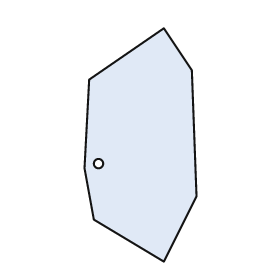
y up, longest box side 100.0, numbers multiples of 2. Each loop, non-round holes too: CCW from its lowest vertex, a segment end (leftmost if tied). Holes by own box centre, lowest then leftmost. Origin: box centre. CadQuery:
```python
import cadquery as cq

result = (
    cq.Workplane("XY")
    .moveTo(10.0, -50.0)
    .lineTo(24.0, -22.0)
    .lineTo(22.0, 32.0)
    .lineTo(10.0, 50.0)
    .lineTo(-22.0, 28.0)
    .lineTo(-24.0, -10.0)
    .lineTo(-20.0, -32.0)
    .close()
    .moveTo(-18.0, -8.0)
    .circle(2.0)
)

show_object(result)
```